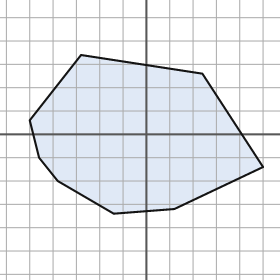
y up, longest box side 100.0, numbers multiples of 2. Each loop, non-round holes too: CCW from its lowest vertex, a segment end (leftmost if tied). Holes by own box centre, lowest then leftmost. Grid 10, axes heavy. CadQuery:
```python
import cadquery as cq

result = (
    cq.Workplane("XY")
    .moveTo(-14.0, -34.0)
    .lineTo(12.0, -32.0)
    .lineTo(50.0, -14.0)
    .lineTo(24.0, 26.0)
    .lineTo(-28.0, 34.0)
    .lineTo(-50.0, 6.0)
    .lineTo(-46.0, -10.0)
    .lineTo(-38.0, -20.0)
    .close()
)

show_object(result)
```